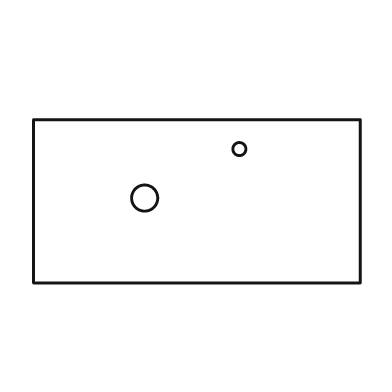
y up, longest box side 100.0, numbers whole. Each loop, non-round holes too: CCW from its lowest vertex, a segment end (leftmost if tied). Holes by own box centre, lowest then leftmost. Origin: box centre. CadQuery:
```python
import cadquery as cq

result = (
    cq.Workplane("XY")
    .moveTo(-50.0, -25.0)
    .lineTo(50.0, -25.0)
    .lineTo(50.0, 25.0)
    .lineTo(-50.0, 25.0)
    .close()
    .moveTo(-16.0, 1.0)
    .circle(4.0)
    .moveTo(13.0, 16.0)
    .circle(2.0)
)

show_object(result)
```